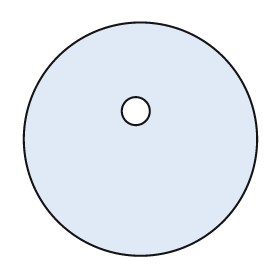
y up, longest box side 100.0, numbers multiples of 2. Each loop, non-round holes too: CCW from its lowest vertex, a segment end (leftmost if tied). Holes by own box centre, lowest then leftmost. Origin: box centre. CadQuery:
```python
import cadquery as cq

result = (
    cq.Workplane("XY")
    .moveTo(0.0, 0.0)
    .circle(50.0)
    .moveTo(-2.0, 12.0)
    .circle(6.0)
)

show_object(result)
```